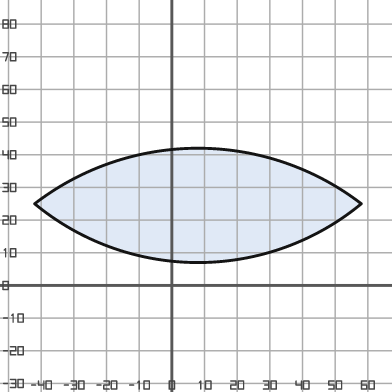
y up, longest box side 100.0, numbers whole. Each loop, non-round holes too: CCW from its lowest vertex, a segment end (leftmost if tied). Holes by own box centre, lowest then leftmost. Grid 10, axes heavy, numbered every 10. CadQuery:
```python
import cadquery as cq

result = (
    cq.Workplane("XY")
    .moveTo(-42.0, 25.0)
    .threePointArc((8.0, 7.0), (58.0, 25.0))
    .threePointArc((8.0, 42.0), (-42.0, 25.0))
    .close()
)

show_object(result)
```